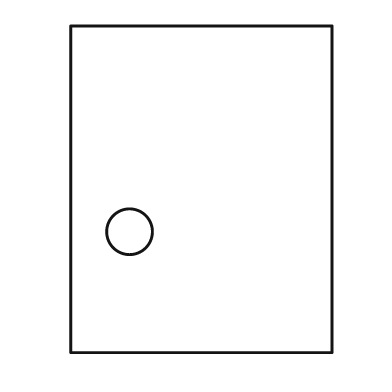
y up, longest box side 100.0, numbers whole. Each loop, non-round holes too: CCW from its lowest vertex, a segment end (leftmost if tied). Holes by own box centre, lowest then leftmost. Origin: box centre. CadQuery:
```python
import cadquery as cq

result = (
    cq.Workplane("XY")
    .moveTo(-40.0, -50.0)
    .lineTo(40.0, -50.0)
    .lineTo(40.0, 50.0)
    .lineTo(-40.0, 50.0)
    .close()
    .moveTo(-22.0, -13.0)
    .circle(7.0)
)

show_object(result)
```